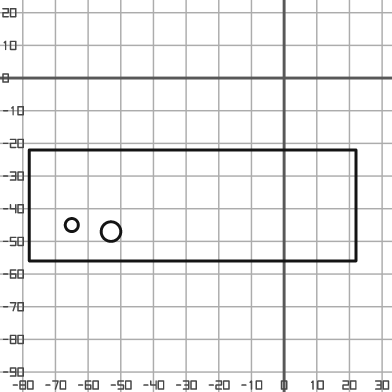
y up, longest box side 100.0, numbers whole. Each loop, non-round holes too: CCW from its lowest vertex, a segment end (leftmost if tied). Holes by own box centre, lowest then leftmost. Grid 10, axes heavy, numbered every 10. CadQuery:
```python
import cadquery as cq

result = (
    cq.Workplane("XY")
    .moveTo(-78.0, -56.0)
    .lineTo(22.0, -56.0)
    .lineTo(22.0, -22.0)
    .lineTo(-78.0, -22.0)
    .close()
    .moveTo(-53.0, -47.0)
    .circle(3.0)
    .moveTo(-65.0, -45.0)
    .circle(2.0)
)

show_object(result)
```